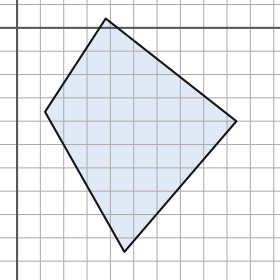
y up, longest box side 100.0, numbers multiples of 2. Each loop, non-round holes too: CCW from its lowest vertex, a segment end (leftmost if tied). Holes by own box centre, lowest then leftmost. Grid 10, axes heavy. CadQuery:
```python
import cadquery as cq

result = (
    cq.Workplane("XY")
    .moveTo(46.0, -96.0)
    .lineTo(94.0, -40.0)
    .lineTo(38.0, 4.0)
    .lineTo(12.0, -36.0)
    .close()
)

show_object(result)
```